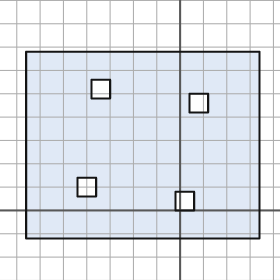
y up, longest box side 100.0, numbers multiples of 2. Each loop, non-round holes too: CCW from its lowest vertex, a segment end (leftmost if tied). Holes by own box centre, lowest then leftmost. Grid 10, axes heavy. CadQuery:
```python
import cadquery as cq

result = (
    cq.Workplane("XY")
    .moveTo(-66.0, -12.0)
    .lineTo(34.0, -12.0)
    .lineTo(34.0, 68.0)
    .lineTo(-66.0, 68.0)
    .close()
    .moveTo(-2.0, 0.0)
    .lineTo(6.0, 0.0)
    .lineTo(6.0, 8.0)
    .lineTo(-2.0, 8.0)
    .close()
    .moveTo(-44.0, 6.0)
    .lineTo(-36.0, 6.0)
    .lineTo(-36.0, 14.0)
    .lineTo(-44.0, 14.0)
    .close()
    .moveTo(4.0, 42.0)
    .lineTo(12.0, 42.0)
    .lineTo(12.0, 50.0)
    .lineTo(4.0, 50.0)
    .close()
    .moveTo(-38.0, 48.0)
    .lineTo(-30.0, 48.0)
    .lineTo(-30.0, 56.0)
    .lineTo(-38.0, 56.0)
    .close()
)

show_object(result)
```